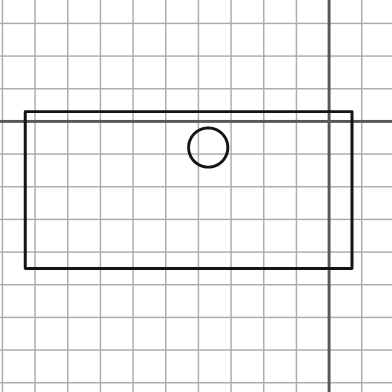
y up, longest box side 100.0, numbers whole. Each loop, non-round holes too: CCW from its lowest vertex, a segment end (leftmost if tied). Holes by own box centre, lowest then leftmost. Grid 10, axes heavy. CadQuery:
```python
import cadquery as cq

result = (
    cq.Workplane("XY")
    .moveTo(-93.0, -45.0)
    .lineTo(7.0, -45.0)
    .lineTo(7.0, 3.0)
    .lineTo(-93.0, 3.0)
    .close()
    .moveTo(-37.0, -8.0)
    .circle(6.0)
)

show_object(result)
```